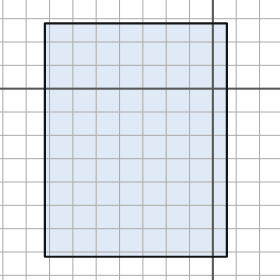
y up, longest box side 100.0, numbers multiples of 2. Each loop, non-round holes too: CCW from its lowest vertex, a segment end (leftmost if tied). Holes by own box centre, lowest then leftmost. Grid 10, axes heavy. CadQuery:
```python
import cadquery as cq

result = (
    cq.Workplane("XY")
    .moveTo(-72.0, -72.0)
    .lineTo(6.0, -72.0)
    .lineTo(6.0, 28.0)
    .lineTo(-72.0, 28.0)
    .close()
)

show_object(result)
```